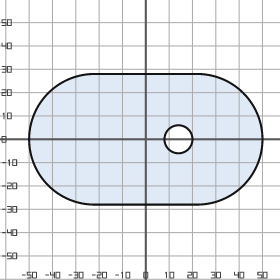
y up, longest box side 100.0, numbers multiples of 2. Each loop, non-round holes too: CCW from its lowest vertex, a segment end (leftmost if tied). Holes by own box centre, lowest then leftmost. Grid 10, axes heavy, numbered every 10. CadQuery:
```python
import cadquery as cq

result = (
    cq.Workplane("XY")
    .moveTo(-22.0, -28.0)
    .lineTo(22.0, -28.0)
    .threePointArc((50.0, 0.0), (22.0, 28.0))
    .lineTo(-22.0, 28.0)
    .threePointArc((-50.0, 0.0), (-22.0, -28.0))
    .close()
    .moveTo(14.0, 0.0)
    .circle(6.0)
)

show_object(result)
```